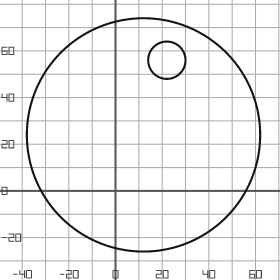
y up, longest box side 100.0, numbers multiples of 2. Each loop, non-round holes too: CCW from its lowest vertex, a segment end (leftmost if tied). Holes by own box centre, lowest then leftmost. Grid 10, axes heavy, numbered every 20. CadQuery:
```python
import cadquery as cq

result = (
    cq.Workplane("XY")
    .moveTo(12.0, 24.0)
    .circle(50.0)
    .moveTo(22.0, 56.0)
    .circle(8.0)
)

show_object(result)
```